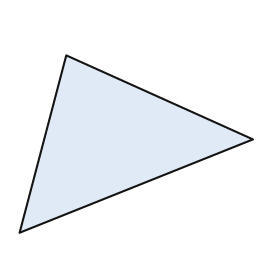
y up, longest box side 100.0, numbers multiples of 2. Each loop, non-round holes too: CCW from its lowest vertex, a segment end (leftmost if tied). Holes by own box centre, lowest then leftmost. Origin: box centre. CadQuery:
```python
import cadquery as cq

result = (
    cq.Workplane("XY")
    .moveTo(-50.0, -38.0)
    .lineTo(50.0, 2.0)
    .lineTo(-30.0, 38.0)
    .close()
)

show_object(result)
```